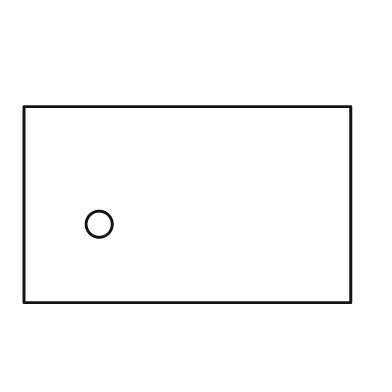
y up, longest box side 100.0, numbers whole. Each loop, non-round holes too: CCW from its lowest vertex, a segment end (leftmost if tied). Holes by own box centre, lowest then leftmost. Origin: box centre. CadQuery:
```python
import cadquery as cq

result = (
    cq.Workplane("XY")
    .moveTo(-50.0, -30.0)
    .lineTo(50.0, -30.0)
    .lineTo(50.0, 30.0)
    .lineTo(-50.0, 30.0)
    .close()
    .moveTo(-27.0, -6.0)
    .circle(4.0)
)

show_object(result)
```